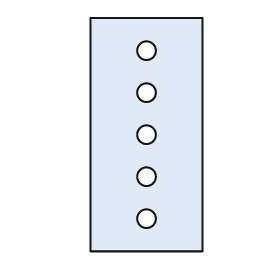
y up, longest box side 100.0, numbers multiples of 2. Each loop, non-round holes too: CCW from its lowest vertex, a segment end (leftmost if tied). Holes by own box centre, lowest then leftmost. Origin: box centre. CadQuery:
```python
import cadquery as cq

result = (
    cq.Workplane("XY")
    .moveTo(-24.0, -50.0)
    .lineTo(24.0, -50.0)
    .lineTo(24.0, 50.0)
    .lineTo(-24.0, 50.0)
    .close()
    .moveTo(0.0, -36.0)
    .circle(4.0)
    .moveTo(0.0, -18.0)
    .circle(4.0)
    .moveTo(0.0, 0.0)
    .circle(4.0)
    .moveTo(0.0, 18.0)
    .circle(4.0)
    .moveTo(0.0, 36.0)
    .circle(4.0)
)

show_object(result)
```